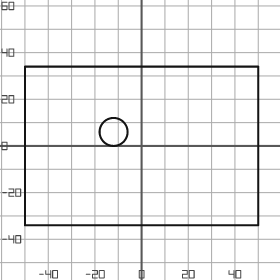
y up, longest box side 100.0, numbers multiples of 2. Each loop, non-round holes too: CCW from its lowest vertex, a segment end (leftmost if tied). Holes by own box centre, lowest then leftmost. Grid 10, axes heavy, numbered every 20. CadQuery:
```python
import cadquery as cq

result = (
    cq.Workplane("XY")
    .moveTo(-50.0, -34.0)
    .lineTo(50.0, -34.0)
    .lineTo(50.0, 34.0)
    .lineTo(-50.0, 34.0)
    .close()
    .moveTo(-12.0, 6.0)
    .circle(6.0)
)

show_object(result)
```